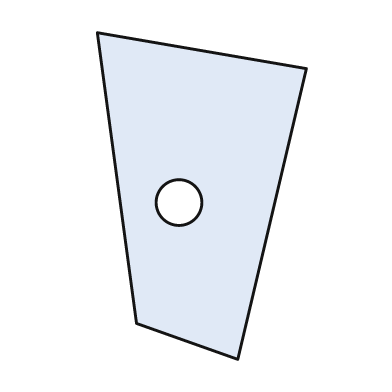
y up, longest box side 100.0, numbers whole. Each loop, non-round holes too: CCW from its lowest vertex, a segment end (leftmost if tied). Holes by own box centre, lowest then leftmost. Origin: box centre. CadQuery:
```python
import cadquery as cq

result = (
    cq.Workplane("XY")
    .moveTo(11.0, -50.0)
    .lineTo(32.0, 39.0)
    .lineTo(-32.0, 50.0)
    .lineTo(-20.0, -39.0)
    .close()
    .moveTo(-7.0, -2.0)
    .circle(7.0)
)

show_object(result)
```